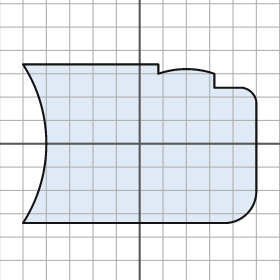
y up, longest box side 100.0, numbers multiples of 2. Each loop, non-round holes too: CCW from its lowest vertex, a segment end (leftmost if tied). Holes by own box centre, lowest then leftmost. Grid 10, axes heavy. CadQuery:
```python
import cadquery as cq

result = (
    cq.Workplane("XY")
    .moveTo(-50.0, -34.0)
    .lineTo(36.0, -34.0)
    .threePointArc((46.0, -30.0), (50.0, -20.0))
    .lineTo(50.0, 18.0)
    .threePointArc((48.0, 22.0), (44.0, 24.0))
    .lineTo(32.0, 24.0)
    .lineTo(32.0, 30.0)
    .threePointArc((20.0, 32.0), (8.0, 30.0))
    .lineTo(8.0, 34.0)
    .lineTo(-50.0, 34.0)
    .threePointArc((-40.0, 0.0), (-50.0, -34.0))
    .close()
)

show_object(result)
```